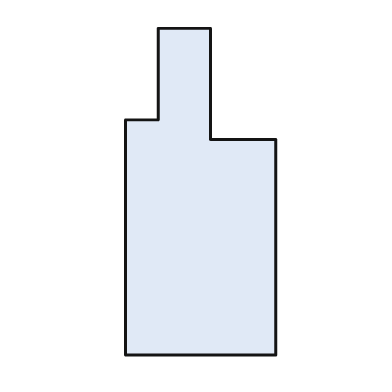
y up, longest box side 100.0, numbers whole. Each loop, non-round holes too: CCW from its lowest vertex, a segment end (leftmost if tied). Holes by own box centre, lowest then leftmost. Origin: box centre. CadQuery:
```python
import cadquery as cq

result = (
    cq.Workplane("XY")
    .moveTo(-23.0, -50.0)
    .lineTo(23.0, -50.0)
    .lineTo(23.0, 16.0)
    .lineTo(3.0, 16.0)
    .lineTo(3.0, 50.0)
    .lineTo(-13.0, 50.0)
    .lineTo(-13.0, 22.0)
    .lineTo(-23.0, 22.0)
    .close()
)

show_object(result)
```